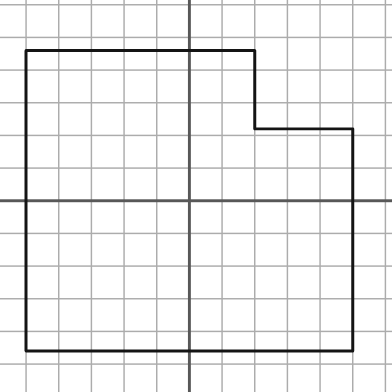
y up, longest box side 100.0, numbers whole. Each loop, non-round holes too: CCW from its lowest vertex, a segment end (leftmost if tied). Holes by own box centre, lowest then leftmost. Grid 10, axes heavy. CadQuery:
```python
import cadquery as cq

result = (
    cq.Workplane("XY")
    .moveTo(-50.0, -46.0)
    .lineTo(50.0, -46.0)
    .lineTo(50.0, 22.0)
    .lineTo(20.0, 22.0)
    .lineTo(20.0, 46.0)
    .lineTo(-50.0, 46.0)
    .close()
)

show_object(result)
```